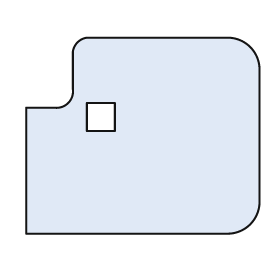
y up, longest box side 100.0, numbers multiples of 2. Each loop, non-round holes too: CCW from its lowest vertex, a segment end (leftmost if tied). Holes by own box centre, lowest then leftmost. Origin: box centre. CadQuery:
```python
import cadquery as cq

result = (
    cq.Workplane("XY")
    .moveTo(-50.0, -42.0)
    .lineTo(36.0, -42.0)
    .threePointArc((46.0, -38.0), (50.0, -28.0))
    .lineTo(50.0, 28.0)
    .threePointArc((46.0, 38.0), (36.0, 42.0))
    .lineTo(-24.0, 42.0)
    .threePointArc((-28.0, 40.0), (-30.0, 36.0))
    .lineTo(-30.0, 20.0)
    .threePointArc((-32.0, 14.0), (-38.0, 12.0))
    .lineTo(-50.0, 12.0)
    .close()
    .moveTo(-24.0, 2.0)
    .lineTo(-12.0, 2.0)
    .lineTo(-12.0, 14.0)
    .lineTo(-24.0, 14.0)
    .close()
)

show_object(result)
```